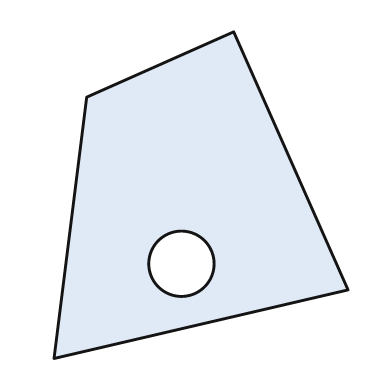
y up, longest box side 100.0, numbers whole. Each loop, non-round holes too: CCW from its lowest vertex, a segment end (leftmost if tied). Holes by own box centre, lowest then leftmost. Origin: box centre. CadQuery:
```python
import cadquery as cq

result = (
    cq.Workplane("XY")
    .moveTo(-45.0, -50.0)
    .lineTo(45.0, -29.0)
    .lineTo(10.0, 50.0)
    .lineTo(-35.0, 30.0)
    .close()
    .moveTo(-6.0, -21.0)
    .circle(10.0)
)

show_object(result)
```